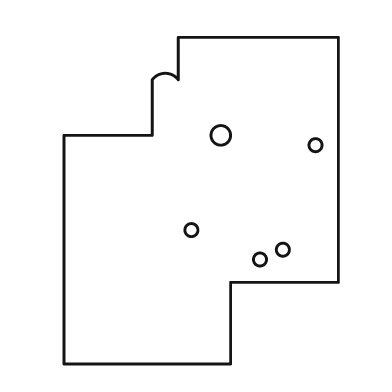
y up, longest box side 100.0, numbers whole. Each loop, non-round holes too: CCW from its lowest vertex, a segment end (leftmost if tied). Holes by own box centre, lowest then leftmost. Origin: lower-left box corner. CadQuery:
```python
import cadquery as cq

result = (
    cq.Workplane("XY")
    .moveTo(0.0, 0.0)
    .lineTo(51.0, 0.0)
    .lineTo(51.0, 25.0)
    .lineTo(84.0, 25.0)
    .lineTo(84.0, 100.0)
    .lineTo(35.0, 100.0)
    .lineTo(35.0, 87.0)
    .threePointArc((31.0, 89.0), (27.0, 87.0))
    .lineTo(27.0, 70.0)
    .lineTo(0.0, 70.0)
    .close()
    .moveTo(60.0, 32.0)
    .circle(2.0)
    .moveTo(67.0, 35.0)
    .circle(2.0)
    .moveTo(39.0, 41.0)
    .circle(2.0)
    .moveTo(77.0, 67.0)
    .circle(2.0)
    .moveTo(48.0, 70.0)
    .circle(3.0)
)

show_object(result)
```